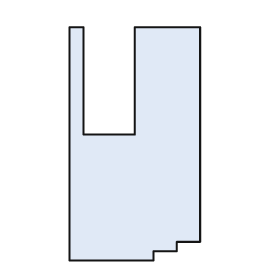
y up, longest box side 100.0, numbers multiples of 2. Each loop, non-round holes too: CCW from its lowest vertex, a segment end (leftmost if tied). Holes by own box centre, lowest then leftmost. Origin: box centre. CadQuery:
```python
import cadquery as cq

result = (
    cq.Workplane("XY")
    .moveTo(-28.0, -50.0)
    .lineTo(8.0, -50.0)
    .lineTo(8.0, -46.0)
    .lineTo(18.0, -46.0)
    .lineTo(18.0, -42.0)
    .lineTo(28.0, -42.0)
    .lineTo(28.0, 50.0)
    .lineTo(0.0, 50.0)
    .lineTo(0.0, 4.0)
    .lineTo(-22.0, 4.0)
    .lineTo(-22.0, 50.0)
    .lineTo(-28.0, 50.0)
    .close()
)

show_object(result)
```